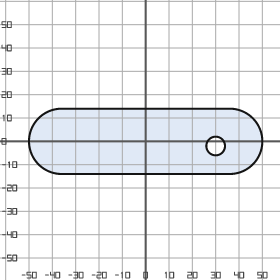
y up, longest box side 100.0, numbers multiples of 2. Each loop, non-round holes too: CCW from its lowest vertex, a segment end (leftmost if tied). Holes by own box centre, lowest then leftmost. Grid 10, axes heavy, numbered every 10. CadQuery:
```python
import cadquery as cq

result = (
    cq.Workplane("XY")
    .moveTo(-36.0, -14.0)
    .lineTo(36.0, -14.0)
    .threePointArc((50.0, 0.0), (36.0, 14.0))
    .lineTo(-36.0, 14.0)
    .threePointArc((-50.0, 0.0), (-36.0, -14.0))
    .close()
    .moveTo(30.0, -2.0)
    .circle(4.0)
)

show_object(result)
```